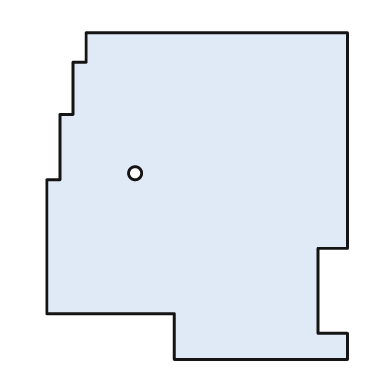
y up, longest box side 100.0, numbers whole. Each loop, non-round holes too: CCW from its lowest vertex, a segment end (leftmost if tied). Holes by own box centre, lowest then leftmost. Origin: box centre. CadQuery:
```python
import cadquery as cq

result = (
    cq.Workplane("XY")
    .moveTo(-7.0, -50.0)
    .lineTo(46.0, -50.0)
    .lineTo(46.0, -42.0)
    .lineTo(37.0, -42.0)
    .lineTo(37.0, -16.0)
    .lineTo(46.0, -16.0)
    .lineTo(46.0, 50.0)
    .lineTo(-34.0, 50.0)
    .lineTo(-34.0, 41.0)
    .lineTo(-38.0, 41.0)
    .lineTo(-38.0, 25.0)
    .lineTo(-42.0, 25.0)
    .lineTo(-42.0, 5.0)
    .lineTo(-46.0, 5.0)
    .lineTo(-46.0, -36.0)
    .lineTo(-7.0, -36.0)
    .close()
    .moveTo(-19.0, 7.0)
    .circle(2.0)
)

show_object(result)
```